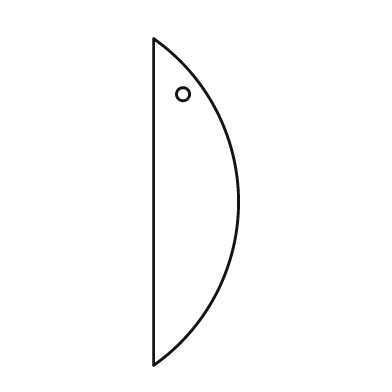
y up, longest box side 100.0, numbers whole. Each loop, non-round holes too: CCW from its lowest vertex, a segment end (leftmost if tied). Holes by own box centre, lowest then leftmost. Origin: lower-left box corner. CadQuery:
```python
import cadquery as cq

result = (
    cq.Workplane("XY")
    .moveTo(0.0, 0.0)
    .threePointArc((26.0, 50.0), (0.0, 100.0))
    .close()
    .moveTo(9.0, 83.0)
    .circle(2.0)
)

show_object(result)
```